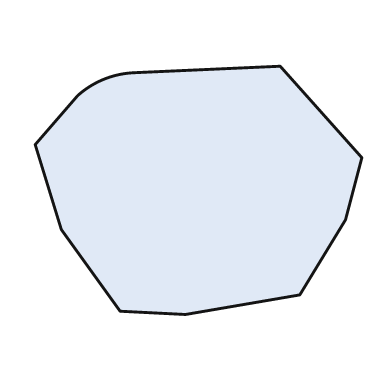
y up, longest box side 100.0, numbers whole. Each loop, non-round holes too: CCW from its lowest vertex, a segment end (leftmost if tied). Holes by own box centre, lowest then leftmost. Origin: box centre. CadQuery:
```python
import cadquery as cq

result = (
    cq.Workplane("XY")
    .moveTo(-4.0, -38.0)
    .lineTo(31.0, -32.0)
    .lineTo(45.0, -9.0)
    .lineTo(50.0, 10.0)
    .lineTo(25.0, 38.0)
    .lineTo(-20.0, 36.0)
    .threePointArc((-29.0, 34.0), (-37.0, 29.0))
    .lineTo(-50.0, 14.0)
    .lineTo(-42.0, -12.0)
    .lineTo(-24.0, -37.0)
    .close()
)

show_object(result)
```